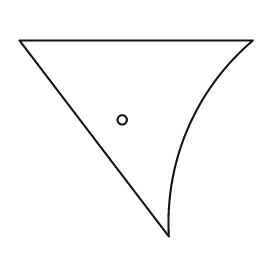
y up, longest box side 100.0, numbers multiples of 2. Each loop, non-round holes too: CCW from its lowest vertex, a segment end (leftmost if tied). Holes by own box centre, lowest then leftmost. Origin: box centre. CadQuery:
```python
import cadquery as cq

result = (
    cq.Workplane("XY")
    .moveTo(14.0, -42.0)
    .threePointArc((22.0, 4.0), (50.0, 42.0))
    .lineTo(-50.0, 42.0)
    .close()
    .moveTo(-6.0, 8.0)
    .circle(2.0)
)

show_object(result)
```